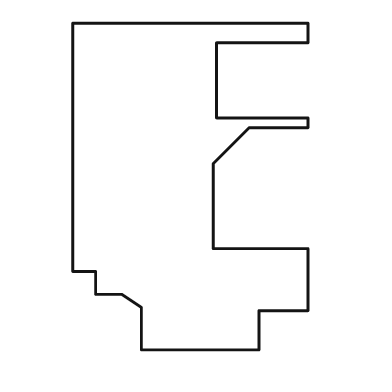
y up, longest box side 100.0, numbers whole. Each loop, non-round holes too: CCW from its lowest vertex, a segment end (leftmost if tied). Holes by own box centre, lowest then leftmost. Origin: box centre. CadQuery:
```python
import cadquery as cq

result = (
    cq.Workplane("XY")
    .moveTo(-15.0, -50.0)
    .lineTo(21.0, -50.0)
    .lineTo(21.0, -38.0)
    .lineTo(36.0, -38.0)
    .lineTo(36.0, -19.0)
    .lineTo(7.0, -19.0)
    .lineTo(7.0, 7.0)
    .lineTo(18.0, 18.0)
    .lineTo(36.0, 18.0)
    .lineTo(36.0, 21.0)
    .lineTo(8.0, 21.0)
    .lineTo(8.0, 44.0)
    .lineTo(36.0, 44.0)
    .lineTo(36.0, 50.0)
    .lineTo(-36.0, 50.0)
    .lineTo(-36.0, -26.0)
    .lineTo(-29.0, -26.0)
    .lineTo(-29.0, -33.0)
    .lineTo(-21.0, -33.0)
    .lineTo(-15.0, -37.0)
    .close()
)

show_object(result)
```